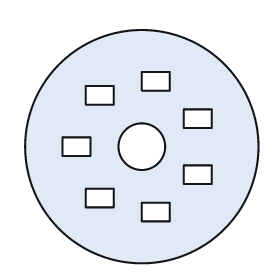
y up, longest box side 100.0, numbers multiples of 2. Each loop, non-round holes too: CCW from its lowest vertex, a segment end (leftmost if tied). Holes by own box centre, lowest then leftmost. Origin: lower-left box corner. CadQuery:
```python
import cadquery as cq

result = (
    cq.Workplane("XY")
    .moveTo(50.0, 50.0)
    .circle(50.0)
    .moveTo(50.0, 18.0)
    .lineTo(62.0, 18.0)
    .lineTo(62.0, 26.0)
    .lineTo(50.0, 26.0)
    .close()
    .moveTo(26.0, 24.0)
    .lineTo(38.0, 24.0)
    .lineTo(38.0, 32.0)
    .lineTo(26.0, 32.0)
    .close()
    .moveTo(68.0, 34.0)
    .lineTo(80.0, 34.0)
    .lineTo(80.0, 42.0)
    .lineTo(68.0, 42.0)
    .close()
    .moveTo(16.0, 46.0)
    .lineTo(28.0, 46.0)
    .lineTo(28.0, 54.0)
    .lineTo(16.0, 54.0)
    .close()
    .moveTo(50.0, 50.0)
    .circle(10.0)
    .moveTo(68.0, 58.0)
    .lineTo(80.0, 58.0)
    .lineTo(80.0, 66.0)
    .lineTo(68.0, 66.0)
    .close()
    .moveTo(26.0, 68.0)
    .lineTo(38.0, 68.0)
    .lineTo(38.0, 76.0)
    .lineTo(26.0, 76.0)
    .close()
    .moveTo(50.0, 74.0)
    .lineTo(62.0, 74.0)
    .lineTo(62.0, 82.0)
    .lineTo(50.0, 82.0)
    .close()
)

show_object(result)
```